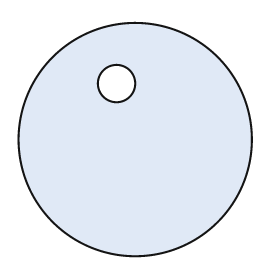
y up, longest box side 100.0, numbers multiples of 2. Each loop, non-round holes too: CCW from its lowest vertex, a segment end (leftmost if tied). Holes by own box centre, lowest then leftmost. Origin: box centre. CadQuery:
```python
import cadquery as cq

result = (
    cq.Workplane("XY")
    .moveTo(0.0, 0.0)
    .circle(50.0)
    .moveTo(-8.0, 24.0)
    .circle(8.0)
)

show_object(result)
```